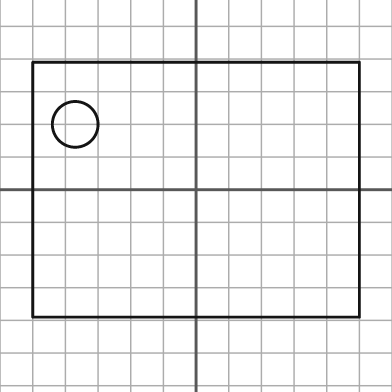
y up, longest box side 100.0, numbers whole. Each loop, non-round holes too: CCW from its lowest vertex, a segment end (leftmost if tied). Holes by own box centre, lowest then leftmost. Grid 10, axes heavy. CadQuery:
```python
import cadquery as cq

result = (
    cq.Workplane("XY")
    .moveTo(-50.0, -39.0)
    .lineTo(50.0, -39.0)
    .lineTo(50.0, 39.0)
    .lineTo(-50.0, 39.0)
    .close()
    .moveTo(-37.0, 20.0)
    .circle(7.0)
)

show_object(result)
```